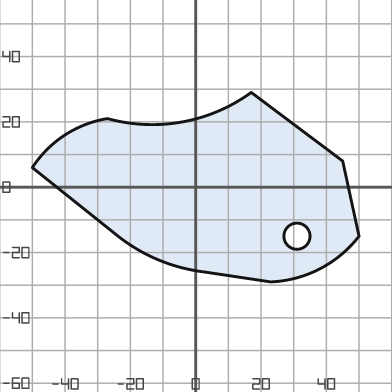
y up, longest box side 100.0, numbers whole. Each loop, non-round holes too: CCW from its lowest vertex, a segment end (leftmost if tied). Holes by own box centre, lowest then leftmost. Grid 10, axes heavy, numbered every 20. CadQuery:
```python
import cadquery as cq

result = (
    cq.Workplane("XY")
    .moveTo(23.0, -29.0)
    .threePointArc((38.0, -25.0), (50.0, -15.0))
    .lineTo(45.0, 8.0)
    .lineTo(17.0, 29.0)
    .threePointArc((-4.0, 20.0), (-27.0, 21.0))
    .threePointArc((-40.0, 16.0), (-50.0, 6.0))
    .lineTo(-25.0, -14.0)
    .threePointArc((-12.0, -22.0), (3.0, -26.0))
    .close()
    .moveTo(31.0, -15.0)
    .circle(4.0)
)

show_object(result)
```